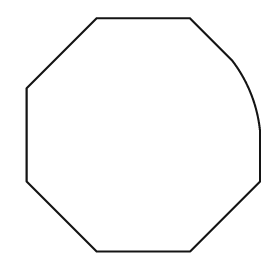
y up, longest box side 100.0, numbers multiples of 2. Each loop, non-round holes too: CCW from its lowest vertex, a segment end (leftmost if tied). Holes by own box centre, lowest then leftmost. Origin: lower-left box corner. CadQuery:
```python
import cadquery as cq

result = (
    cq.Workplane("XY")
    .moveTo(30.0, 0.0)
    .lineTo(70.0, 0.0)
    .lineTo(100.0, 30.0)
    .lineTo(100.0, 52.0)
    .threePointArc((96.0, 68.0), (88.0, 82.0))
    .lineTo(70.0, 100.0)
    .lineTo(30.0, 100.0)
    .lineTo(0.0, 70.0)
    .lineTo(0.0, 30.0)
    .close()
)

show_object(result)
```